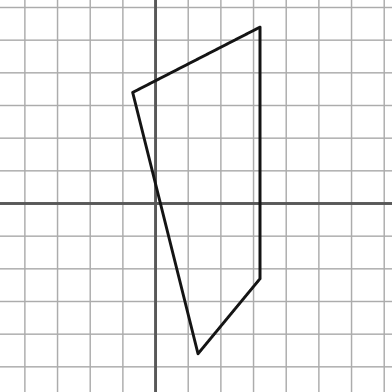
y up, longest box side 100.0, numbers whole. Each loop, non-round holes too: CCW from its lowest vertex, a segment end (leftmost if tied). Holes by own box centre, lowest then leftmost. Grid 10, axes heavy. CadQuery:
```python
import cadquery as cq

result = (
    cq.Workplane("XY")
    .moveTo(13.0, -46.0)
    .lineTo(32.0, -23.0)
    .lineTo(32.0, 54.0)
    .lineTo(-7.0, 34.0)
    .close()
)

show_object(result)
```